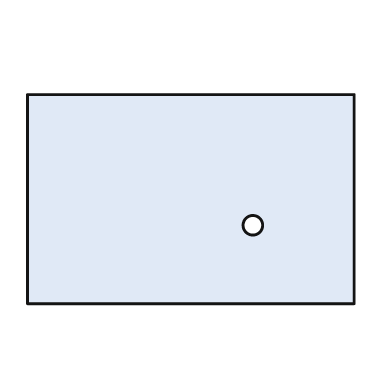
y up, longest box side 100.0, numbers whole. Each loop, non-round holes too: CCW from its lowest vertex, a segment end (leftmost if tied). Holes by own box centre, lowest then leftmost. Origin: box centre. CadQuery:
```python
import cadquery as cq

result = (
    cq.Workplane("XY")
    .moveTo(-50.0, -32.0)
    .lineTo(50.0, -32.0)
    .lineTo(50.0, 32.0)
    .lineTo(-50.0, 32.0)
    .close()
    .moveTo(19.0, -8.0)
    .circle(3.0)
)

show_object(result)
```